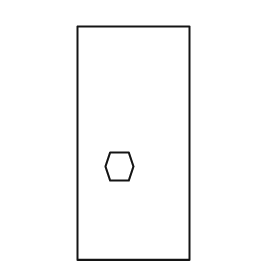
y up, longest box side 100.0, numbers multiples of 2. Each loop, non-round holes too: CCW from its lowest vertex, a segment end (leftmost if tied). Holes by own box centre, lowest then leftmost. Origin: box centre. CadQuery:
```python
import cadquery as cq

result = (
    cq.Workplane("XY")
    .moveTo(-24.0, -50.0)
    .lineTo(24.0, -50.0)
    .lineTo(24.0, 50.0)
    .lineTo(-24.0, 50.0)
    .close()
    .moveTo(-10.0, -16.0)
    .lineTo(-2.0, -16.0)
    .lineTo(0.0, -10.0)
    .lineTo(-2.0, -4.0)
    .lineTo(-10.0, -4.0)
    .lineTo(-12.0, -10.0)
    .close()
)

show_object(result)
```